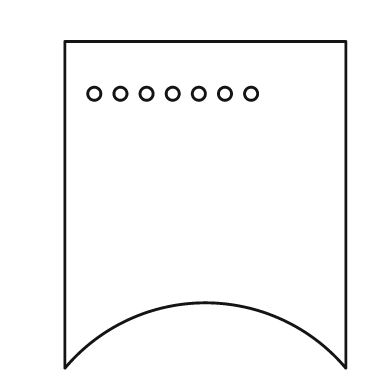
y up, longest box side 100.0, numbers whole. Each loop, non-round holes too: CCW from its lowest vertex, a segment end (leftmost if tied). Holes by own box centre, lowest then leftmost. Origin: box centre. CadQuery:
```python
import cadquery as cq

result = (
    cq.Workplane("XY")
    .moveTo(-43.0, -50.0)
    .threePointArc((0.0, -30.0), (43.0, -50.0))
    .lineTo(43.0, 50.0)
    .lineTo(-43.0, 50.0)
    .close()
    .moveTo(-34.0, 34.0)
    .circle(2.0)
    .moveTo(-26.0, 34.0)
    .circle(2.0)
    .moveTo(-18.0, 34.0)
    .circle(2.0)
    .moveTo(-10.0, 34.0)
    .circle(2.0)
    .moveTo(-2.0, 34.0)
    .circle(2.0)
    .moveTo(6.0, 34.0)
    .circle(2.0)
    .moveTo(14.0, 34.0)
    .circle(2.0)
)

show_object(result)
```